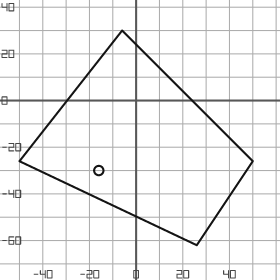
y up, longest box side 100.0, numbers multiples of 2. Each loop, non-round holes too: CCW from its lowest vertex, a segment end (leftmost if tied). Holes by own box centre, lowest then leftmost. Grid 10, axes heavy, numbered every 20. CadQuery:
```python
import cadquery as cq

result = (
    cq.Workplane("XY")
    .moveTo(26.0, -62.0)
    .lineTo(50.0, -26.0)
    .lineTo(-6.0, 30.0)
    .lineTo(-50.0, -26.0)
    .close()
    .moveTo(-16.0, -30.0)
    .circle(2.0)
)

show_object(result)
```